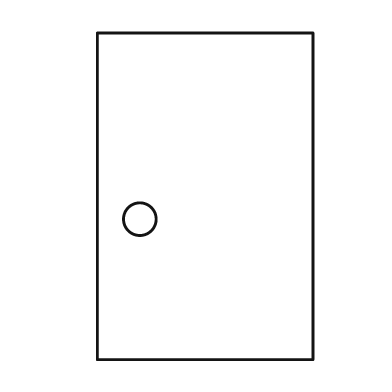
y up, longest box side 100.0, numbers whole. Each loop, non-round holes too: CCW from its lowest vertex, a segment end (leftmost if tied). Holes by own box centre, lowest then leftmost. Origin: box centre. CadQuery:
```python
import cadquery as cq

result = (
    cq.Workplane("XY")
    .moveTo(-33.0, -50.0)
    .lineTo(33.0, -50.0)
    .lineTo(33.0, 50.0)
    .lineTo(-33.0, 50.0)
    .close()
    .moveTo(-20.0, -7.0)
    .circle(5.0)
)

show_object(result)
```